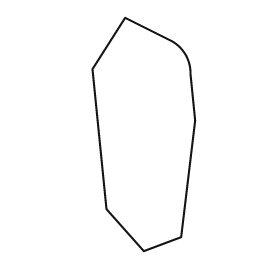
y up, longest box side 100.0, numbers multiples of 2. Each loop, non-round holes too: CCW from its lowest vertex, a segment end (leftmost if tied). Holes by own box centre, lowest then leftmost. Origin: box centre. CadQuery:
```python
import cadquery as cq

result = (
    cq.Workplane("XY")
    .moveTo(0.0, -50.0)
    .lineTo(16.0, -44.0)
    .lineTo(22.0, 6.0)
    .lineTo(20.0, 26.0)
    .threePointArc((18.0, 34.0), (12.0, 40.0))
    .lineTo(-8.0, 50.0)
    .lineTo(-22.0, 28.0)
    .lineTo(-16.0, -32.0)
    .close()
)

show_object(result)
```